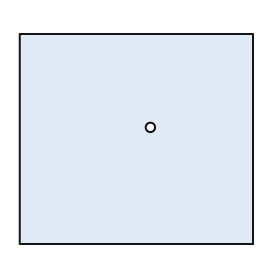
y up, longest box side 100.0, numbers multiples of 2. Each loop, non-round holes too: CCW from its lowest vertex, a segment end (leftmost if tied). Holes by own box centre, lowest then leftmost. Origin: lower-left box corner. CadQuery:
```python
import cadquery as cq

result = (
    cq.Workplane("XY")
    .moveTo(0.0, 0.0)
    .lineTo(100.0, 0.0)
    .lineTo(100.0, 90.0)
    .lineTo(0.0, 90.0)
    .close()
    .moveTo(56.0, 50.0)
    .circle(2.0)
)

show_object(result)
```